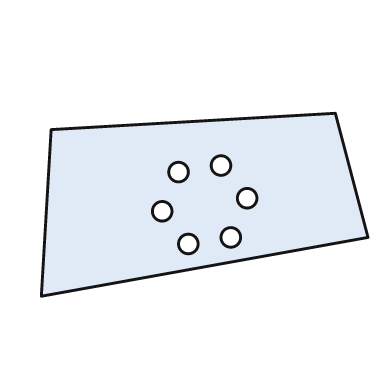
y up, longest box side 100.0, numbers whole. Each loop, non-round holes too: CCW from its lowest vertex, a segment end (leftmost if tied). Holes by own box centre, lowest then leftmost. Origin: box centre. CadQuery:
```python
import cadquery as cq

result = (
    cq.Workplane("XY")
    .moveTo(-50.0, -28.0)
    .lineTo(50.0, -10.0)
    .lineTo(40.0, 28.0)
    .lineTo(-47.0, 23.0)
    .close()
    .moveTo(-5.0, -12.0)
    .circle(3.0)
    .moveTo(8.0, -10.0)
    .circle(3.0)
    .moveTo(-13.0, -2.0)
    .circle(3.0)
    .moveTo(13.0, 2.0)
    .circle(3.0)
    .moveTo(-8.0, 10.0)
    .circle(3.0)
    .moveTo(5.0, 12.0)
    .circle(3.0)
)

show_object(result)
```